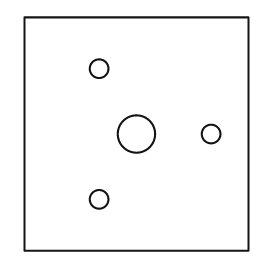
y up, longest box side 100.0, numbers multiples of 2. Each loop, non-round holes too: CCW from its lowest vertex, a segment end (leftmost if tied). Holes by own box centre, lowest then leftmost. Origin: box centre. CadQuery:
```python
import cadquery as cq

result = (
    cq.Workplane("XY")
    .moveTo(-48.0, -50.0)
    .lineTo(48.0, -50.0)
    .lineTo(48.0, 50.0)
    .lineTo(-48.0, 50.0)
    .close()
    .moveTo(-16.0, -28.0)
    .circle(4.0)
    .moveTo(0.0, 0.0)
    .circle(8.0)
    .moveTo(32.0, 0.0)
    .circle(4.0)
    .moveTo(-16.0, 28.0)
    .circle(4.0)
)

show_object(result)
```